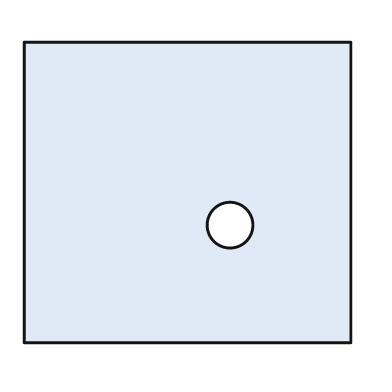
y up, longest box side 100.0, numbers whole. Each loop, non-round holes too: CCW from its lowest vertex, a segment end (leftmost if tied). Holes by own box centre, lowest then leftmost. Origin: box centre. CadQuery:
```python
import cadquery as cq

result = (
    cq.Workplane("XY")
    .moveTo(-50.0, -46.0)
    .lineTo(50.0, -46.0)
    .lineTo(50.0, 46.0)
    .lineTo(-50.0, 46.0)
    .close()
    .moveTo(13.0, -10.0)
    .circle(7.0)
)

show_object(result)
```